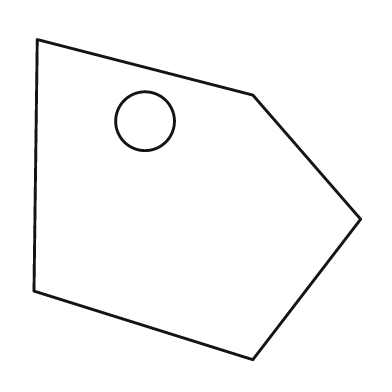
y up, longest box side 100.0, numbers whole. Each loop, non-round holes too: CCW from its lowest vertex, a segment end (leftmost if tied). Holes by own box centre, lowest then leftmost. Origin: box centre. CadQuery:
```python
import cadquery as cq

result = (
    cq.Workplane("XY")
    .moveTo(17.0, -49.0)
    .lineTo(50.0, -6.0)
    .lineTo(17.0, 32.0)
    .lineTo(-49.0, 49.0)
    .lineTo(-50.0, -28.0)
    .close()
    .moveTo(-16.0, 24.0)
    .circle(9.0)
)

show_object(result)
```